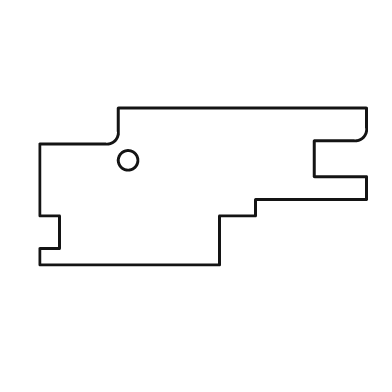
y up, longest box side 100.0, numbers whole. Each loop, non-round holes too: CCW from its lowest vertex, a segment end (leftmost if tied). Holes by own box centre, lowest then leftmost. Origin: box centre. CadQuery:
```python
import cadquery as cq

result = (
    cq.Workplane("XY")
    .moveTo(-50.0, -24.0)
    .lineTo(5.0, -24.0)
    .lineTo(5.0, -9.0)
    .lineTo(16.0, -9.0)
    .lineTo(16.0, -4.0)
    .lineTo(50.0, -4.0)
    .lineTo(50.0, 3.0)
    .lineTo(34.0, 3.0)
    .lineTo(34.0, 14.0)
    .lineTo(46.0, 14.0)
    .threePointArc((49.0, 15.0), (50.0, 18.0))
    .lineTo(50.0, 24.0)
    .lineTo(-26.0, 24.0)
    .lineTo(-26.0, 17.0)
    .threePointArc((-27.0, 14.0), (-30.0, 13.0))
    .lineTo(-50.0, 13.0)
    .lineTo(-50.0, -9.0)
    .lineTo(-44.0, -9.0)
    .lineTo(-44.0, -19.0)
    .lineTo(-50.0, -19.0)
    .close()
    .moveTo(-23.0, 8.0)
    .circle(3.0)
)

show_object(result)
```